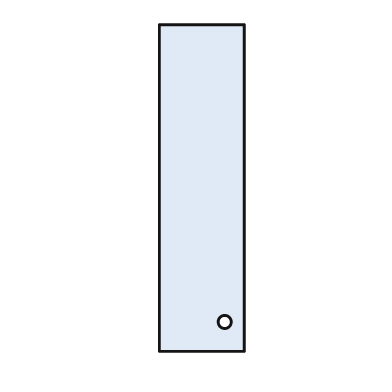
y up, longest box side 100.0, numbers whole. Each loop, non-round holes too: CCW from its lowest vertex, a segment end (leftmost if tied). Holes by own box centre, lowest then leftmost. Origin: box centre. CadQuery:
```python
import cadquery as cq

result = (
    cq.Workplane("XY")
    .moveTo(-13.0, -50.0)
    .lineTo(13.0, -50.0)
    .lineTo(13.0, 50.0)
    .lineTo(-13.0, 50.0)
    .close()
    .moveTo(7.0, -41.0)
    .circle(2.0)
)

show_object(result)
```